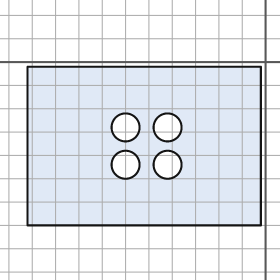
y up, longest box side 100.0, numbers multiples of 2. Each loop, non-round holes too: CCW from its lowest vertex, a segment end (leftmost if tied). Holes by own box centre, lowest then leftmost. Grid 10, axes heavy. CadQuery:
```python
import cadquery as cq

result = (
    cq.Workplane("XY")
    .moveTo(-102.0, -70.0)
    .lineTo(-2.0, -70.0)
    .lineTo(-2.0, -2.0)
    .lineTo(-102.0, -2.0)
    .close()
    .moveTo(-60.0, -44.0)
    .circle(6.0)
    .moveTo(-42.0, -44.0)
    .circle(6.0)
    .moveTo(-60.0, -28.0)
    .circle(6.0)
    .moveTo(-42.0, -28.0)
    .circle(6.0)
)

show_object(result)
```